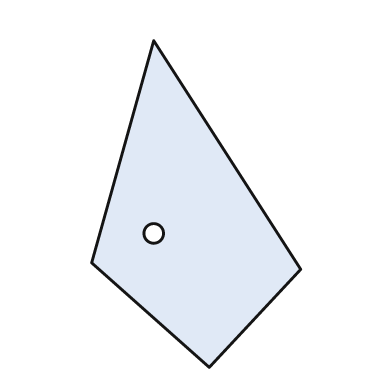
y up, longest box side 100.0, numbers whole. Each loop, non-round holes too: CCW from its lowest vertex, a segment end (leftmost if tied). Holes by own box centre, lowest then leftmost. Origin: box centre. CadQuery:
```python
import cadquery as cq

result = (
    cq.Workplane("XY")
    .moveTo(4.0, -50.0)
    .lineTo(32.0, -20.0)
    .lineTo(-13.0, 50.0)
    .lineTo(-32.0, -18.0)
    .close()
    .moveTo(-13.0, -9.0)
    .circle(3.0)
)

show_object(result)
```